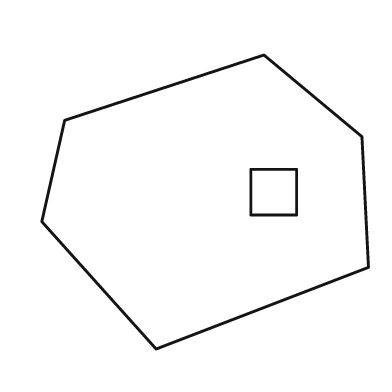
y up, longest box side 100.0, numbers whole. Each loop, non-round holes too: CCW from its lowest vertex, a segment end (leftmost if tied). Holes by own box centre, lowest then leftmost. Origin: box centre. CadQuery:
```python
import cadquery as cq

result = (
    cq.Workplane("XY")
    .moveTo(-15.0, -45.0)
    .lineTo(50.0, -20.0)
    .lineTo(48.0, 20.0)
    .lineTo(18.0, 45.0)
    .lineTo(-43.0, 25.0)
    .lineTo(-50.0, -6.0)
    .close()
    .moveTo(14.0, -4.0)
    .lineTo(28.0, -4.0)
    .lineTo(28.0, 10.0)
    .lineTo(14.0, 10.0)
    .close()
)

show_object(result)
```